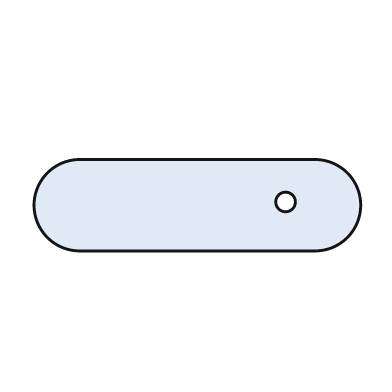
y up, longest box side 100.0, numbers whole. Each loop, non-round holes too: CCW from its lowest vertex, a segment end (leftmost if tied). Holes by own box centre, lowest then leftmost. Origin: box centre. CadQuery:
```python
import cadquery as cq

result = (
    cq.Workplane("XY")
    .moveTo(-36.0, -14.0)
    .lineTo(36.0, -14.0)
    .threePointArc((50.0, 0.0), (36.0, 14.0))
    .lineTo(-36.0, 14.0)
    .threePointArc((-50.0, 0.0), (-36.0, -14.0))
    .close()
    .moveTo(27.0, 1.0)
    .circle(3.0)
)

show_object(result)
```